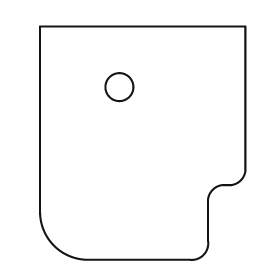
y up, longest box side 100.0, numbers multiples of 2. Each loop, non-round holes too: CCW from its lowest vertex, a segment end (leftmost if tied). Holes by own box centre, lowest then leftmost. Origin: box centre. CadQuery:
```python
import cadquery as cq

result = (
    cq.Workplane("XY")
    .moveTo(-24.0, -50.0)
    .lineTo(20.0, -50.0)
    .threePointArc((26.0, -48.0), (28.0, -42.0))
    .lineTo(28.0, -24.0)
    .threePointArc((30.0, -20.0), (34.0, -18.0))
    .lineTo(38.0, -18.0)
    .threePointArc((42.0, -16.0), (44.0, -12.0))
    .lineTo(44.0, 50.0)
    .lineTo(-44.0, 50.0)
    .lineTo(-44.0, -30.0)
    .threePointArc((-38.0, -44.0), (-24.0, -50.0))
    .close()
    .moveTo(-10.0, 24.0)
    .circle(6.0)
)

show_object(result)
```